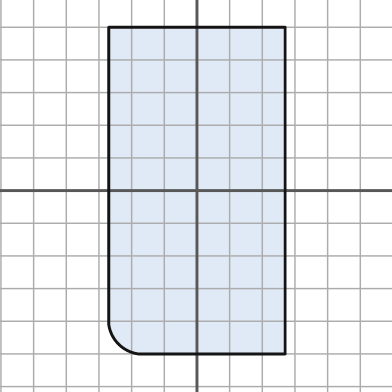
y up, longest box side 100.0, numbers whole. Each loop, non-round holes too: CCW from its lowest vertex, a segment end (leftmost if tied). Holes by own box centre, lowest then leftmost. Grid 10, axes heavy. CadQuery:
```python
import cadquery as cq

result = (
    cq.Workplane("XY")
    .moveTo(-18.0, -50.0)
    .lineTo(27.0, -50.0)
    .lineTo(27.0, 50.0)
    .lineTo(-27.0, 50.0)
    .lineTo(-27.0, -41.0)
    .threePointArc((-24.0, -47.0), (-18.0, -50.0))
    .close()
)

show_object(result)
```